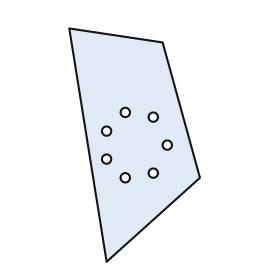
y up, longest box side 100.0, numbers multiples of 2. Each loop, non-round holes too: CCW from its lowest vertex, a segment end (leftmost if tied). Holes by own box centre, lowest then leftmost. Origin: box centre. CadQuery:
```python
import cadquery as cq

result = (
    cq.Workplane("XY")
    .moveTo(-12.0, -50.0)
    .lineTo(28.0, -14.0)
    .lineTo(12.0, 44.0)
    .lineTo(-28.0, 50.0)
    .close()
    .moveTo(-4.0, -14.0)
    .circle(2.0)
    .moveTo(8.0, -12.0)
    .circle(2.0)
    .moveTo(-12.0, -6.0)
    .circle(2.0)
    .moveTo(14.0, 0.0)
    .circle(2.0)
    .moveTo(-12.0, 6.0)
    .circle(2.0)
    .moveTo(8.0, 12.0)
    .circle(2.0)
    .moveTo(-4.0, 14.0)
    .circle(2.0)
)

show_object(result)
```